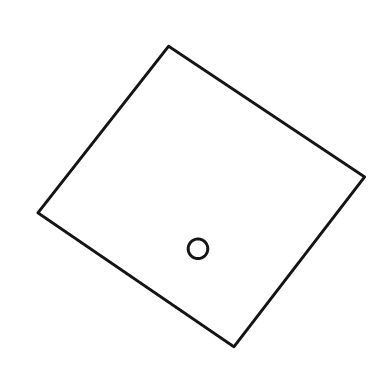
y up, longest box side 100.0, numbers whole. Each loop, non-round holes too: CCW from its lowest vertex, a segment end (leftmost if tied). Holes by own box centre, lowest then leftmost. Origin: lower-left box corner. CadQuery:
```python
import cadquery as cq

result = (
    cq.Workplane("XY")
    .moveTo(60.0, 0.0)
    .lineTo(100.0, 52.0)
    .lineTo(40.0, 92.0)
    .lineTo(0.0, 41.0)
    .close()
    .moveTo(49.0, 30.0)
    .circle(3.0)
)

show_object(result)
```